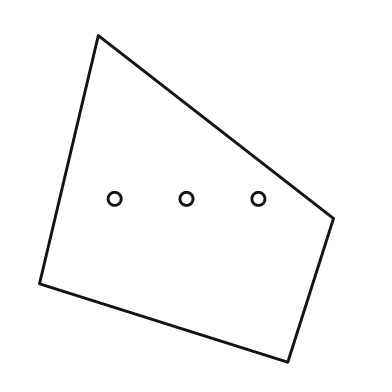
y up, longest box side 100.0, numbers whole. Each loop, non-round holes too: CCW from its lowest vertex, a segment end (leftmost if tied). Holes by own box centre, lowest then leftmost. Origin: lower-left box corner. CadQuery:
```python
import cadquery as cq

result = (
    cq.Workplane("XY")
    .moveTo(76.0, 0.0)
    .lineTo(90.0, 44.0)
    .lineTo(18.0, 100.0)
    .lineTo(0.0, 24.0)
    .close()
    .moveTo(23.0, 50.0)
    .circle(2.0)
    .moveTo(45.0, 50.0)
    .circle(2.0)
    .moveTo(67.0, 50.0)
    .circle(2.0)
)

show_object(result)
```